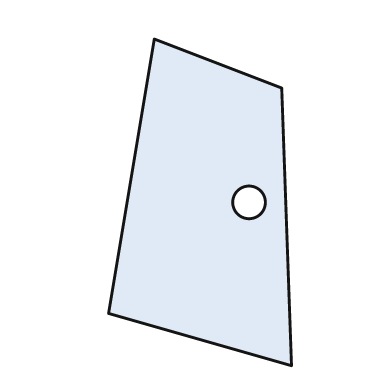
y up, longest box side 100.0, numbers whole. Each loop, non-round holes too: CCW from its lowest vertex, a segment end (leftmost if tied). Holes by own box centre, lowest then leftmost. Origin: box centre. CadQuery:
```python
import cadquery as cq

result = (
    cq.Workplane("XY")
    .moveTo(28.0, -50.0)
    .lineTo(25.0, 35.0)
    .lineTo(-14.0, 50.0)
    .lineTo(-28.0, -34.0)
    .close()
    .moveTo(15.0, 0.0)
    .circle(5.0)
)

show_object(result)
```